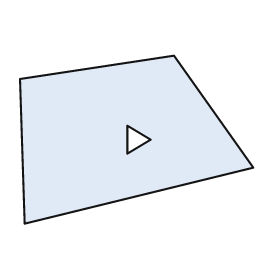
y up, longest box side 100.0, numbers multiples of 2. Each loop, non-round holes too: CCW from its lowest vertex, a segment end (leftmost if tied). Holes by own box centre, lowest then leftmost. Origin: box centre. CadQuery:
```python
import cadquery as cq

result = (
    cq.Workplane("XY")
    .moveTo(-48.0, -36.0)
    .lineTo(50.0, -12.0)
    .lineTo(16.0, 36.0)
    .lineTo(-50.0, 26.0)
    .close()
    .moveTo(-4.0, -6.0)
    .lineTo(6.0, 0.0)
    .lineTo(-4.0, 6.0)
    .close()
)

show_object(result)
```